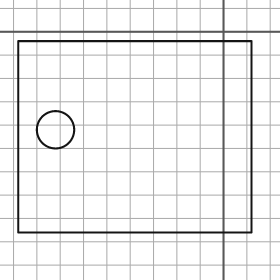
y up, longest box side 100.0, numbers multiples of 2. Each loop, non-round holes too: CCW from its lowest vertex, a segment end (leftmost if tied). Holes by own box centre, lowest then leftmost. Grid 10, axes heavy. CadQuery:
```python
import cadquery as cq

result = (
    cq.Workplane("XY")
    .moveTo(-88.0, -86.0)
    .lineTo(12.0, -86.0)
    .lineTo(12.0, -4.0)
    .lineTo(-88.0, -4.0)
    .close()
    .moveTo(-72.0, -42.0)
    .circle(8.0)
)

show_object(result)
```